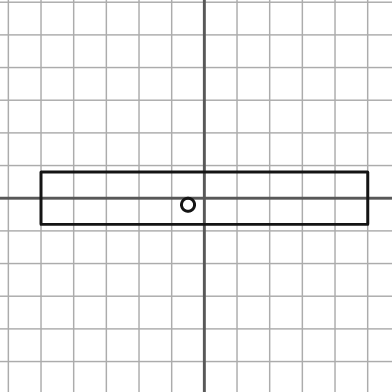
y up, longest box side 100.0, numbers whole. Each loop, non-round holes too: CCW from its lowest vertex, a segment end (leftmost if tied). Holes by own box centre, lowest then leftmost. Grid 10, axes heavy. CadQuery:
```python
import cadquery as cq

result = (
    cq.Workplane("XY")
    .moveTo(-50.0, -8.0)
    .lineTo(50.0, -8.0)
    .lineTo(50.0, 8.0)
    .lineTo(-50.0, 8.0)
    .close()
    .moveTo(-5.0, -2.0)
    .circle(2.0)
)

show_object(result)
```